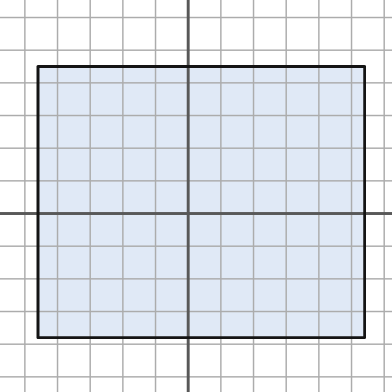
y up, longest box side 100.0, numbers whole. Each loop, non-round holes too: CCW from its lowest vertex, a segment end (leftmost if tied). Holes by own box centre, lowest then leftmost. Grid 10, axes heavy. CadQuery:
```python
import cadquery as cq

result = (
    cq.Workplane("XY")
    .moveTo(-46.0, -38.0)
    .lineTo(54.0, -38.0)
    .lineTo(54.0, 45.0)
    .lineTo(-46.0, 45.0)
    .close()
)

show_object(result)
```